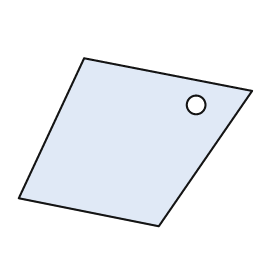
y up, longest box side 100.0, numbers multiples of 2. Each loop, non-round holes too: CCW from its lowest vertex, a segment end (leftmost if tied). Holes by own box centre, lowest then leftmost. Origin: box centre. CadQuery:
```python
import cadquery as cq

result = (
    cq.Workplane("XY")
    .moveTo(10.0, -36.0)
    .lineTo(50.0, 22.0)
    .lineTo(-22.0, 36.0)
    .lineTo(-50.0, -24.0)
    .close()
    .moveTo(26.0, 16.0)
    .circle(4.0)
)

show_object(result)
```